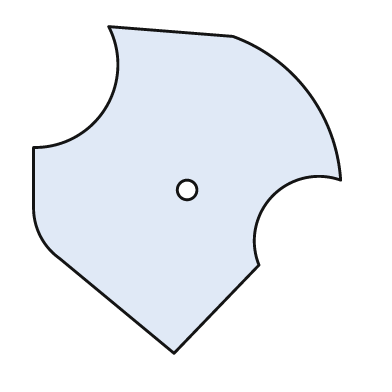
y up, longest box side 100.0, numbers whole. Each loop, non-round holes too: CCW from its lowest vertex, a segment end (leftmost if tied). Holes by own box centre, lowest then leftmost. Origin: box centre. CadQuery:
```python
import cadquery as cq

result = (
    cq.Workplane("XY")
    .moveTo(-4.0, -50.0)
    .lineTo(22.0, -23.0)
    .threePointArc((26.0, -2.0), (47.0, 3.0))
    .threePointArc((37.0, 30.0), (14.0, 47.0))
    .lineTo(-24.0, 50.0)
    .threePointArc((-25.0, 25.0), (-47.0, 13.0))
    .lineTo(-47.0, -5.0)
    .threePointArc((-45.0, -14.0), (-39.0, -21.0))
    .close()
    .moveTo(0.0, 0.0)
    .circle(3.0)
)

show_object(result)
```